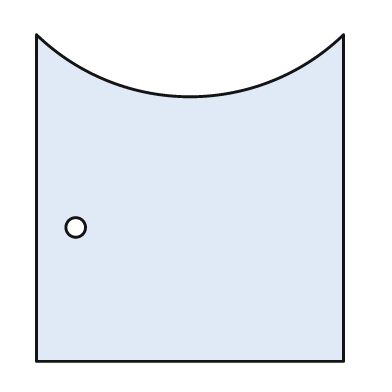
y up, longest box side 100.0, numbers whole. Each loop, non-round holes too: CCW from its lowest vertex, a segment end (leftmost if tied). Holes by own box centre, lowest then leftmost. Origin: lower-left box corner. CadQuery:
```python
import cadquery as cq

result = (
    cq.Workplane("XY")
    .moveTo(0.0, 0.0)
    .lineTo(94.0, 0.0)
    .lineTo(94.0, 100.0)
    .threePointArc((47.0, 81.0), (0.0, 100.0))
    .close()
    .moveTo(12.0, 41.0)
    .circle(3.0)
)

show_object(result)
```